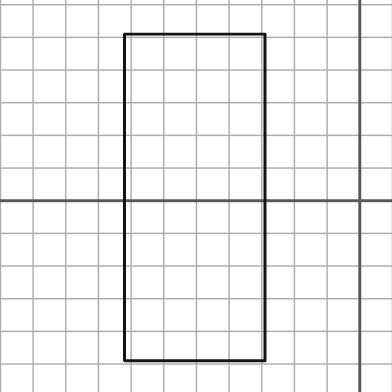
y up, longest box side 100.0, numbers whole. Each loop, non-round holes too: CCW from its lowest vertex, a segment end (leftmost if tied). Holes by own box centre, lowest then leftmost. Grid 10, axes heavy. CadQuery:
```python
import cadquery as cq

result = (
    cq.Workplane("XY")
    .moveTo(-72.0, -49.0)
    .lineTo(-29.0, -49.0)
    .lineTo(-29.0, 51.0)
    .lineTo(-72.0, 51.0)
    .close()
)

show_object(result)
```